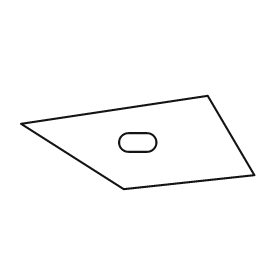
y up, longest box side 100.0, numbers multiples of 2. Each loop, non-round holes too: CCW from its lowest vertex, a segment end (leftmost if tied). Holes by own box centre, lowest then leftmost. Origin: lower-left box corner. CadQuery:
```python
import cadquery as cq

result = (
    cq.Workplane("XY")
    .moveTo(44.0, 0.0)
    .lineTo(100.0, 6.0)
    .lineTo(80.0, 40.0)
    .lineTo(0.0, 28.0)
    .close()
    .moveTo(46.0, 16.0)
    .lineTo(54.0, 16.0)
    .threePointArc((58.0, 20.0), (54.0, 24.0))
    .lineTo(46.0, 24.0)
    .threePointArc((42.0, 20.0), (46.0, 16.0))
    .close()
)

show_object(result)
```